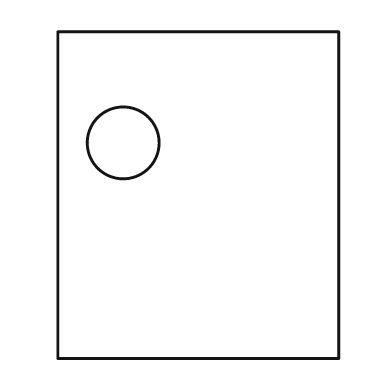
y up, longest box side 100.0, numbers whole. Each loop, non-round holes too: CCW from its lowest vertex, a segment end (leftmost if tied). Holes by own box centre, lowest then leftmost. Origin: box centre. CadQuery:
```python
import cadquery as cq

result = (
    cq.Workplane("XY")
    .moveTo(-43.0, -50.0)
    .lineTo(43.0, -50.0)
    .lineTo(43.0, 50.0)
    .lineTo(-43.0, 50.0)
    .close()
    .moveTo(-23.0, 16.0)
    .circle(11.0)
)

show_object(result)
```